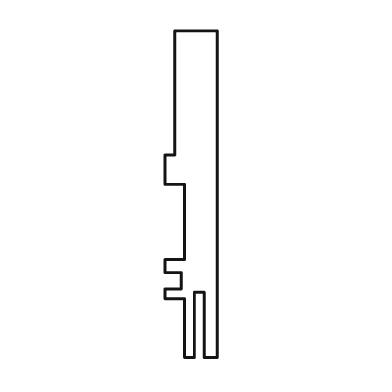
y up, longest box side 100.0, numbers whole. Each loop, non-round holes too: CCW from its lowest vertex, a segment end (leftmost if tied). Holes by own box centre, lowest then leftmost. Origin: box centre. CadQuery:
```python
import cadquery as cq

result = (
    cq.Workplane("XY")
    .moveTo(-2.0, -50.0)
    .lineTo(1.0, -50.0)
    .lineTo(1.0, -30.0)
    .lineTo(4.0, -30.0)
    .lineTo(4.0, -50.0)
    .lineTo(8.0, -50.0)
    .lineTo(8.0, 50.0)
    .lineTo(-5.0, 50.0)
    .lineTo(-5.0, 12.0)
    .lineTo(-8.0, 12.0)
    .lineTo(-8.0, 3.0)
    .lineTo(-2.0, 3.0)
    .lineTo(-2.0, -20.0)
    .lineTo(-8.0, -20.0)
    .lineTo(-8.0, -24.0)
    .lineTo(-3.0, -24.0)
    .lineTo(-3.0, -29.0)
    .lineTo(-8.0, -29.0)
    .lineTo(-8.0, -32.0)
    .lineTo(-2.0, -32.0)
    .close()
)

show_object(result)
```